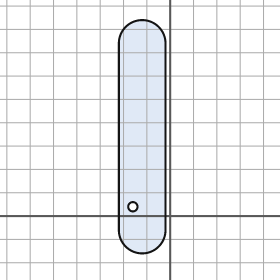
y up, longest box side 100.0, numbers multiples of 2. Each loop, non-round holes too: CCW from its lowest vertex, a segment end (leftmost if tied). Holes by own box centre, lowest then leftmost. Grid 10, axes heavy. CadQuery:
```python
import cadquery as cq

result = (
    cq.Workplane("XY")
    .moveTo(-22.0, -6.0)
    .threePointArc((-12.0, -16.0), (-2.0, -6.0))
    .lineTo(-2.0, 74.0)
    .threePointArc((-12.0, 84.0), (-22.0, 74.0))
    .close()
    .moveTo(-16.0, 4.0)
    .circle(2.0)
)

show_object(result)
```